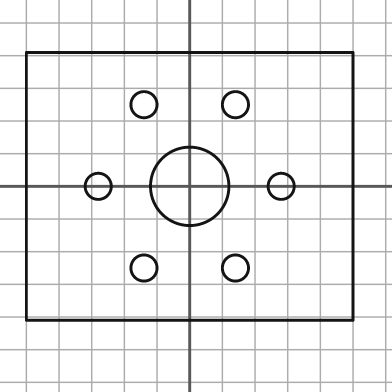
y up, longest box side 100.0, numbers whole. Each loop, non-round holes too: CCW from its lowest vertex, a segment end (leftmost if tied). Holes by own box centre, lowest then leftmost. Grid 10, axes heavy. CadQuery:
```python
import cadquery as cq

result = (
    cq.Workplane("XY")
    .moveTo(-50.0, -41.0)
    .lineTo(50.0, -41.0)
    .lineTo(50.0, 41.0)
    .lineTo(-50.0, 41.0)
    .close()
    .moveTo(-14.0, -25.0)
    .circle(4.0)
    .moveTo(14.0, -25.0)
    .circle(4.0)
    .moveTo(-28.0, 0.0)
    .circle(4.0)
    .moveTo(0.0, 0.0)
    .circle(12.0)
    .moveTo(28.0, 0.0)
    .circle(4.0)
    .moveTo(-14.0, 25.0)
    .circle(4.0)
    .moveTo(14.0, 25.0)
    .circle(4.0)
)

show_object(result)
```